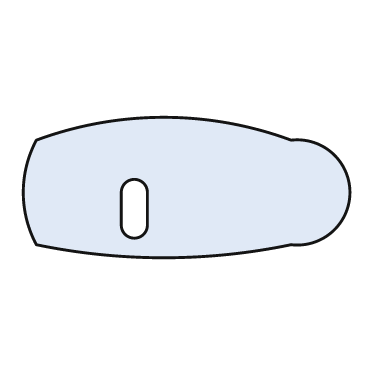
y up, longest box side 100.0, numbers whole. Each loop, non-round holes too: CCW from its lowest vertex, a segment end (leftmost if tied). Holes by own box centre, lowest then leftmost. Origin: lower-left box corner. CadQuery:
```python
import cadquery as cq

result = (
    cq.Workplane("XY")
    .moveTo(4.0, 4.0)
    .threePointArc((43.0, 0.0), (82.0, 4.0))
    .threePointArc((100.0, 20.0), (82.0, 36.0))
    .threePointArc((43.0, 43.0), (4.0, 36.0))
    .threePointArc((0.0, 20.0), (4.0, 4.0))
    .close()
    .moveTo(30.0, 10.0)
    .threePointArc((34.0, 6.0), (38.0, 10.0))
    .lineTo(38.0, 20.0)
    .threePointArc((34.0, 24.0), (30.0, 20.0))
    .close()
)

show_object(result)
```